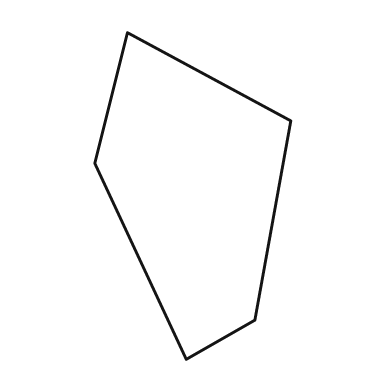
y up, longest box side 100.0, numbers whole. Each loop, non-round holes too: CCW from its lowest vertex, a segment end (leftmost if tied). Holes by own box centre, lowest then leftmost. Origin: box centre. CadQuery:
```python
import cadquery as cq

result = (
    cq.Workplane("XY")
    .moveTo(-2.0, -50.0)
    .lineTo(19.0, -38.0)
    .lineTo(30.0, 23.0)
    .lineTo(-20.0, 50.0)
    .lineTo(-30.0, 10.0)
    .close()
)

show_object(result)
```